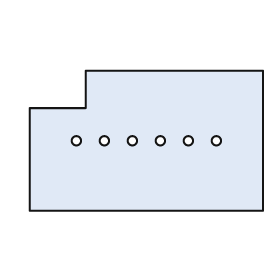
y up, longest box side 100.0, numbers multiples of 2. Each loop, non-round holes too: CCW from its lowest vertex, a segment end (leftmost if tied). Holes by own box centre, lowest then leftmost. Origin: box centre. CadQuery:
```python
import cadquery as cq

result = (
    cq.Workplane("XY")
    .moveTo(-50.0, -30.0)
    .lineTo(50.0, -30.0)
    .lineTo(50.0, 30.0)
    .lineTo(-26.0, 30.0)
    .lineTo(-26.0, 14.0)
    .lineTo(-50.0, 14.0)
    .close()
    .moveTo(-30.0, 0.0)
    .circle(2.0)
    .moveTo(-18.0, 0.0)
    .circle(2.0)
    .moveTo(-6.0, 0.0)
    .circle(2.0)
    .moveTo(6.0, 0.0)
    .circle(2.0)
    .moveTo(18.0, 0.0)
    .circle(2.0)
    .moveTo(30.0, 0.0)
    .circle(2.0)
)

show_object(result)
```